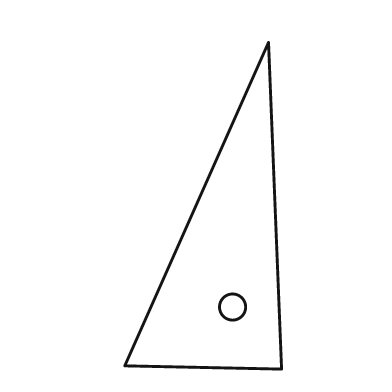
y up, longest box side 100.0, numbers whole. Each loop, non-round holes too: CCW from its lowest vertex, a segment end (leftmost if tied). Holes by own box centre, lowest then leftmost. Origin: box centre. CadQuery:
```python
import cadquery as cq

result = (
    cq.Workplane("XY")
    .moveTo(24.0, -50.0)
    .lineTo(20.0, 50.0)
    .lineTo(-24.0, -49.0)
    .close()
    .moveTo(9.0, -31.0)
    .circle(4.0)
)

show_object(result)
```